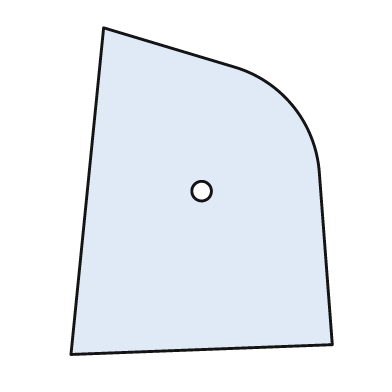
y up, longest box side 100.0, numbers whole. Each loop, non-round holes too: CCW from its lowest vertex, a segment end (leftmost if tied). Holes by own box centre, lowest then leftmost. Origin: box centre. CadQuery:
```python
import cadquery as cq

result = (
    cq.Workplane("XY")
    .moveTo(-40.0, -50.0)
    .lineTo(40.0, -47.0)
    .lineTo(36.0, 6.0)
    .threePointArc((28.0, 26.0), (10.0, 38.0))
    .lineTo(-30.0, 50.0)
    .close()
    .moveTo(0.0, 0.0)
    .circle(3.0)
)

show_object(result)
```